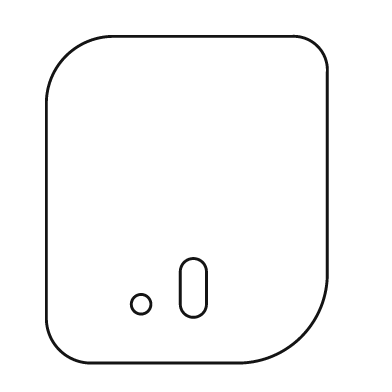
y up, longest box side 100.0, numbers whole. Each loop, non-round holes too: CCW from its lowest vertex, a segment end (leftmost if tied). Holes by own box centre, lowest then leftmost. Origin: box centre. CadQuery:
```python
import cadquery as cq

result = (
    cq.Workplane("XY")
    .moveTo(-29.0, -50.0)
    .lineTo(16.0, -50.0)
    .threePointArc((35.0, -42.0), (43.0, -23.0))
    .lineTo(43.0, 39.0)
    .threePointArc((40.0, 47.0), (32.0, 50.0))
    .lineTo(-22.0, 50.0)
    .threePointArc((-37.0, 44.0), (-43.0, 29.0))
    .lineTo(-43.0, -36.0)
    .threePointArc((-39.0, -46.0), (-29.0, -50.0))
    .close()
    .moveTo(-14.0, -32.0)
    .circle(3.0)
    .moveTo(-2.0, -32.0)
    .threePointArc((2.0, -36.0), (6.0, -32.0))
    .lineTo(6.0, -22.0)
    .threePointArc((2.0, -18.0), (-2.0, -22.0))
    .close()
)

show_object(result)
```